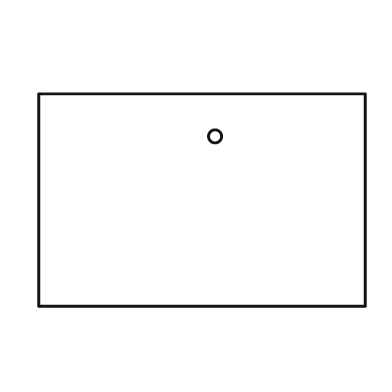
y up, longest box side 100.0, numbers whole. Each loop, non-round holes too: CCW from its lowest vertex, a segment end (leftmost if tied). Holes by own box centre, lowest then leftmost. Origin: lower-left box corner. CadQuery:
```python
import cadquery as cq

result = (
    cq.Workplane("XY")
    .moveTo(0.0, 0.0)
    .lineTo(100.0, 0.0)
    .lineTo(100.0, 65.0)
    .lineTo(0.0, 65.0)
    .close()
    .moveTo(54.0, 52.0)
    .circle(2.0)
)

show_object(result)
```